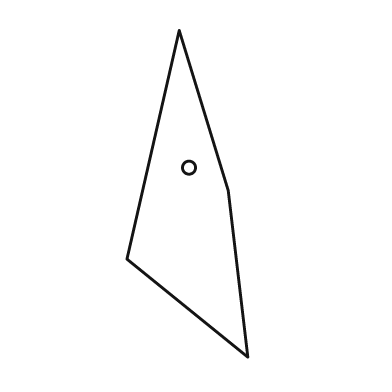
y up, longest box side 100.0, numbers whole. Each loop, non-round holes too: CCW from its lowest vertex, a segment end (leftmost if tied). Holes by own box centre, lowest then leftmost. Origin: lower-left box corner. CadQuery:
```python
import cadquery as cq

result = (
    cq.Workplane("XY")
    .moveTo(37.0, 0.0)
    .lineTo(31.0, 51.0)
    .lineTo(16.0, 100.0)
    .lineTo(0.0, 30.0)
    .close()
    .moveTo(19.0, 58.0)
    .circle(2.0)
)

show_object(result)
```